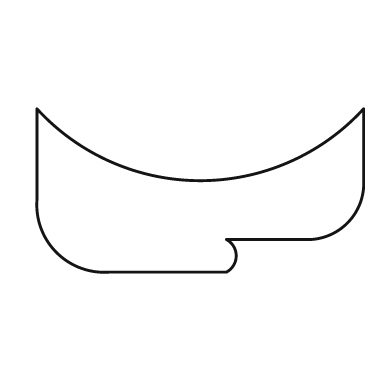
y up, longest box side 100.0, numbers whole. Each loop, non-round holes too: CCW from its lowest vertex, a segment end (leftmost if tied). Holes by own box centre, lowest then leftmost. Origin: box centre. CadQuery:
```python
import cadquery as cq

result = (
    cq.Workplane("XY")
    .moveTo(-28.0, -25.0)
    .lineTo(8.0, -25.0)
    .threePointArc((11.0, -20.0), (8.0, -15.0))
    .lineTo(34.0, -15.0)
    .threePointArc((45.0, -10.0), (50.0, 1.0))
    .lineTo(50.0, 25.0)
    .threePointArc((0.0, 3.0), (-50.0, 25.0))
    .lineTo(-50.0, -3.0)
    .threePointArc((-44.0, -19.0), (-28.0, -25.0))
    .close()
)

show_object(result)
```